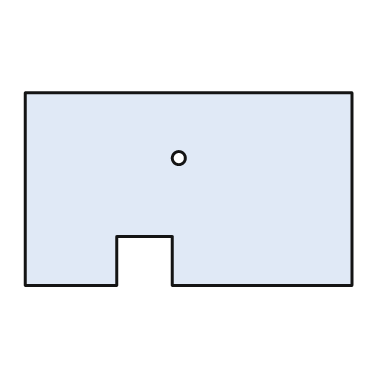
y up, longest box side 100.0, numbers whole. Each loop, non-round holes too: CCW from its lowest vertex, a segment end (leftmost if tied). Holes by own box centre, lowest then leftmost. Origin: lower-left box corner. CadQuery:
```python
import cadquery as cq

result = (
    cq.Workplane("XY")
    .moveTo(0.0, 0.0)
    .lineTo(28.0, 0.0)
    .lineTo(28.0, 15.0)
    .lineTo(45.0, 15.0)
    .lineTo(45.0, 0.0)
    .lineTo(100.0, 0.0)
    .lineTo(100.0, 59.0)
    .lineTo(0.0, 59.0)
    .close()
    .moveTo(47.0, 39.0)
    .circle(2.0)
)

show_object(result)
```